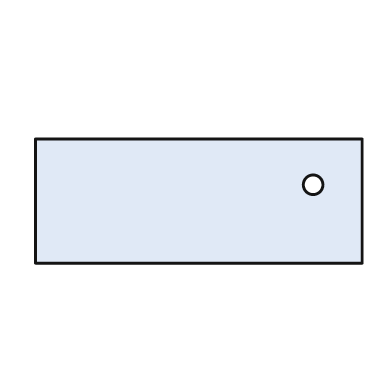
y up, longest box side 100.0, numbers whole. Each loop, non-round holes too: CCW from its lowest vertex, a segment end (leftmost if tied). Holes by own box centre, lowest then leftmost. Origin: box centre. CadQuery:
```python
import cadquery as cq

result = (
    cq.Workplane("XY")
    .moveTo(-50.0, -19.0)
    .lineTo(50.0, -19.0)
    .lineTo(50.0, 19.0)
    .lineTo(-50.0, 19.0)
    .close()
    .moveTo(35.0, 5.0)
    .circle(3.0)
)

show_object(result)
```